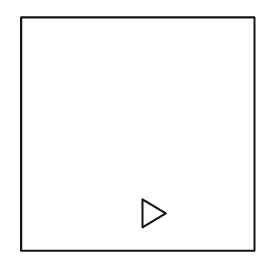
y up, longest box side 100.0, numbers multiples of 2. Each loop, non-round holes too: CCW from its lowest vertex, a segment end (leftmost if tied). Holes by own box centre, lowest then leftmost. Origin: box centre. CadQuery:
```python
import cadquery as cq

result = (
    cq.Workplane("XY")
    .moveTo(-50.0, -50.0)
    .lineTo(50.0, -50.0)
    .lineTo(50.0, 50.0)
    .lineTo(-50.0, 50.0)
    .close()
    .moveTo(2.0, -40.0)
    .lineTo(12.0, -34.0)
    .lineTo(2.0, -28.0)
    .close()
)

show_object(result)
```